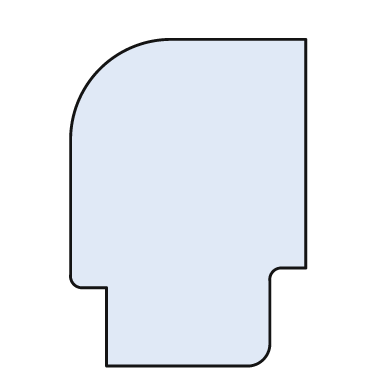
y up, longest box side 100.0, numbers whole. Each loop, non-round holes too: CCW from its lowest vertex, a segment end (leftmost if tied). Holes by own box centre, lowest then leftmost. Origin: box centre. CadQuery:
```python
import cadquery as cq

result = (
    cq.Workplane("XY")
    .moveTo(-25.0, -50.0)
    .lineTo(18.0, -50.0)
    .threePointArc((23.0, -48.0), (25.0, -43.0))
    .lineTo(25.0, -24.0)
    .threePointArc((26.0, -21.0), (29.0, -20.0))
    .lineTo(36.0, -20.0)
    .lineTo(36.0, 50.0)
    .lineTo(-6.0, 50.0)
    .threePointArc((-27.0, 41.0), (-36.0, 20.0))
    .lineTo(-36.0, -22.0)
    .threePointArc((-35.0, -25.0), (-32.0, -26.0))
    .lineTo(-25.0, -26.0)
    .close()
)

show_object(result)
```